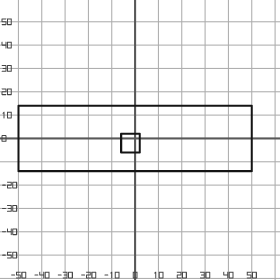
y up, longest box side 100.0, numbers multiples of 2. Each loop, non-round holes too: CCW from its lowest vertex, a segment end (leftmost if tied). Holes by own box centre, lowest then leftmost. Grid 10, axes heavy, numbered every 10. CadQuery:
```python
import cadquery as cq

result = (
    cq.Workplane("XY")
    .moveTo(-50.0, -14.0)
    .lineTo(50.0, -14.0)
    .lineTo(50.0, 14.0)
    .lineTo(-50.0, 14.0)
    .close()
    .moveTo(-6.0, -6.0)
    .lineTo(2.0, -6.0)
    .lineTo(2.0, 2.0)
    .lineTo(-6.0, 2.0)
    .close()
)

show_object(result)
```